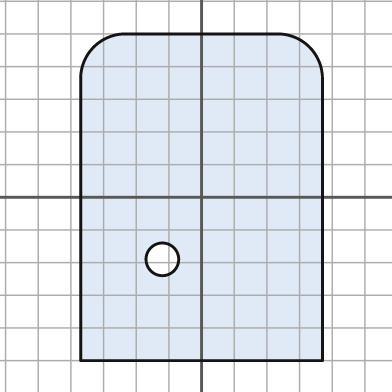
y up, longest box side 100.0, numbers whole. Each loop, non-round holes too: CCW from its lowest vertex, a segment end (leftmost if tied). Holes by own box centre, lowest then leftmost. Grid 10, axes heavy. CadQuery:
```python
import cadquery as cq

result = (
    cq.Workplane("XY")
    .moveTo(-37.0, -50.0)
    .lineTo(37.0, -50.0)
    .lineTo(37.0, 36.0)
    .threePointArc((33.0, 46.0), (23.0, 50.0))
    .lineTo(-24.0, 50.0)
    .threePointArc((-33.0, 46.0), (-37.0, 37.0))
    .close()
    .moveTo(-12.0, -19.0)
    .circle(5.0)
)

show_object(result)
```